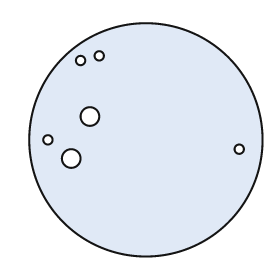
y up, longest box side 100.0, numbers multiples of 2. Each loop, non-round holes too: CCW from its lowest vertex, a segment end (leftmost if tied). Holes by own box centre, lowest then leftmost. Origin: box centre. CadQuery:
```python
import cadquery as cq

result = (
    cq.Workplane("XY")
    .moveTo(0.0, 0.0)
    .circle(50.0)
    .moveTo(-32.0, -8.0)
    .circle(4.0)
    .moveTo(40.0, -4.0)
    .circle(2.0)
    .moveTo(-42.0, 0.0)
    .circle(2.0)
    .moveTo(-24.0, 10.0)
    .circle(4.0)
    .moveTo(-28.0, 34.0)
    .circle(2.0)
    .moveTo(-20.0, 36.0)
    .circle(2.0)
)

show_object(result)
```